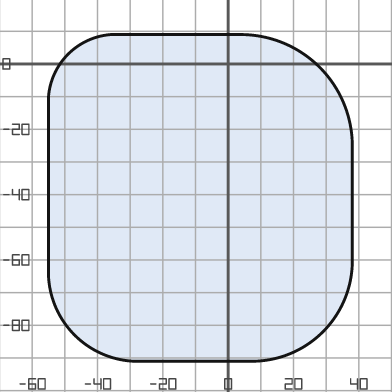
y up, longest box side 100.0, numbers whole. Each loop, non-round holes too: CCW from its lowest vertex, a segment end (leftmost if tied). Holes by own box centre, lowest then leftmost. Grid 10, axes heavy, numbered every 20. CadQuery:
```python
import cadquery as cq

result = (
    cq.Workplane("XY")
    .moveTo(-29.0, -91.0)
    .lineTo(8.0, -91.0)
    .threePointArc((29.0, -82.0), (38.0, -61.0))
    .lineTo(38.0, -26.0)
    .threePointArc((28.0, -1.0), (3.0, 9.0))
    .lineTo(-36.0, 9.0)
    .threePointArc((-49.0, 3.0), (-55.0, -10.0))
    .lineTo(-55.0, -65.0)
    .threePointArc((-47.0, -83.0), (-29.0, -91.0))
    .close()
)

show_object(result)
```